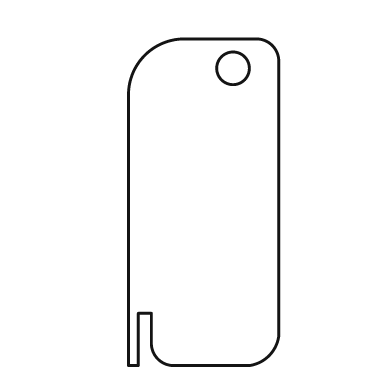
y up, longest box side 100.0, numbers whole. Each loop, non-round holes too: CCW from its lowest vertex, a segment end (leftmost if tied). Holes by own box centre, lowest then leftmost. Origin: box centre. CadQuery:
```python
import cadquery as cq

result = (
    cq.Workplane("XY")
    .moveTo(-23.0, -50.0)
    .lineTo(-20.0, -50.0)
    .lineTo(-20.0, -34.0)
    .lineTo(-16.0, -34.0)
    .lineTo(-16.0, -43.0)
    .threePointArc((-14.0, -48.0), (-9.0, -50.0))
    .lineTo(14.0, -50.0)
    .threePointArc((20.0, -47.0), (23.0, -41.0))
    .lineTo(23.0, 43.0)
    .threePointArc((21.0, 48.0), (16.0, 50.0))
    .lineTo(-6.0, 50.0)
    .threePointArc((-18.0, 45.0), (-23.0, 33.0))
    .close()
    .moveTo(9.0, 41.0)
    .circle(5.0)
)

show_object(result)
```